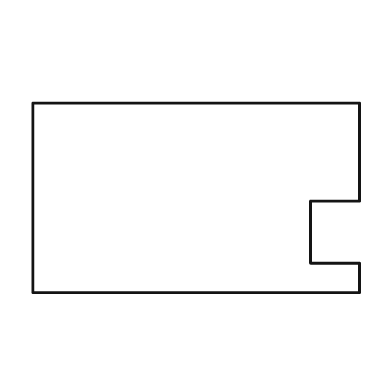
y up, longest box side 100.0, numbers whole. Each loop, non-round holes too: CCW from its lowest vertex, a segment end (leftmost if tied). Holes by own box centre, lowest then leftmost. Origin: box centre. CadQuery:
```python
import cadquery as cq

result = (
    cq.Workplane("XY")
    .moveTo(-50.0, -29.0)
    .lineTo(50.0, -29.0)
    .lineTo(50.0, -20.0)
    .lineTo(35.0, -20.0)
    .lineTo(35.0, -1.0)
    .lineTo(50.0, -1.0)
    .lineTo(50.0, 29.0)
    .lineTo(-50.0, 29.0)
    .close()
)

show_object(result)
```